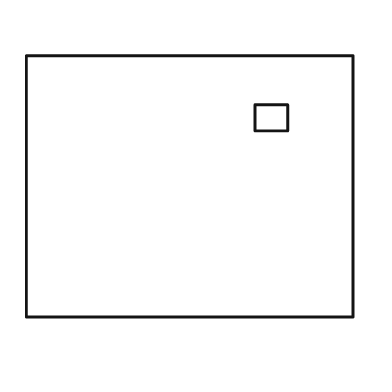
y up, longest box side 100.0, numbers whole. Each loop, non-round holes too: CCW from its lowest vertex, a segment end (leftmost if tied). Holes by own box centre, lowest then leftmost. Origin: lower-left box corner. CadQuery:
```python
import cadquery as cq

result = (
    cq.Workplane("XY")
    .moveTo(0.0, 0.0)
    .lineTo(100.0, 0.0)
    .lineTo(100.0, 80.0)
    .lineTo(0.0, 80.0)
    .close()
    .moveTo(70.0, 57.0)
    .lineTo(80.0, 57.0)
    .lineTo(80.0, 65.0)
    .lineTo(70.0, 65.0)
    .close()
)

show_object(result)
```